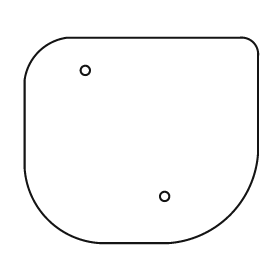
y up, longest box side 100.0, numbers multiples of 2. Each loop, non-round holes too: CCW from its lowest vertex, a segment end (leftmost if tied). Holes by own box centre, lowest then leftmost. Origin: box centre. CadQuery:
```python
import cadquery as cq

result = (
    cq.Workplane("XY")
    .moveTo(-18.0, -44.0)
    .lineTo(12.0, -44.0)
    .threePointArc((38.0, -32.0), (50.0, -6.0))
    .lineTo(50.0, 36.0)
    .threePointArc((48.0, 42.0), (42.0, 44.0))
    .lineTo(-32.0, 44.0)
    .threePointArc((-44.0, 38.0), (-50.0, 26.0))
    .lineTo(-50.0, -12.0)
    .threePointArc((-40.0, -34.0), (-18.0, -44.0))
    .close()
    .moveTo(10.0, -24.0)
    .circle(2.0)
    .moveTo(-24.0, 30.0)
    .circle(2.0)
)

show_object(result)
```